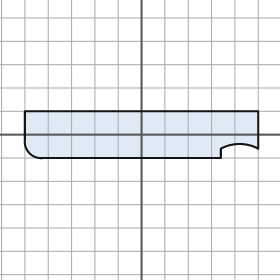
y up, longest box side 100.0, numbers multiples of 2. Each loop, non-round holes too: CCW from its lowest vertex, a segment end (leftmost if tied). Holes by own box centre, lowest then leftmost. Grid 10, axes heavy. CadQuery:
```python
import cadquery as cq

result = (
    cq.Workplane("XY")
    .moveTo(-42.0, -10.0)
    .lineTo(34.0, -10.0)
    .lineTo(34.0, -6.0)
    .threePointArc((42.0, -4.0), (50.0, -6.0))
    .lineTo(50.0, 10.0)
    .lineTo(-50.0, 10.0)
    .lineTo(-50.0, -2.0)
    .threePointArc((-48.0, -8.0), (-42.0, -10.0))
    .close()
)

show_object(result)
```